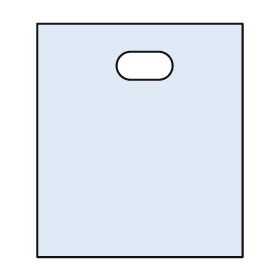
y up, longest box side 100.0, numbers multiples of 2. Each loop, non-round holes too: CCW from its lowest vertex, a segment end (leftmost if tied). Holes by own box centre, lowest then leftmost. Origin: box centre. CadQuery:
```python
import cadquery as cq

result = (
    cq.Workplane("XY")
    .moveTo(-44.0, -50.0)
    .lineTo(44.0, -50.0)
    .lineTo(44.0, 50.0)
    .lineTo(-44.0, 50.0)
    .close()
    .moveTo(-4.0, 26.0)
    .lineTo(8.0, 26.0)
    .threePointArc((14.0, 32.0), (8.0, 38.0))
    .lineTo(-4.0, 38.0)
    .threePointArc((-10.0, 32.0), (-4.0, 26.0))
    .close()
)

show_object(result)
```